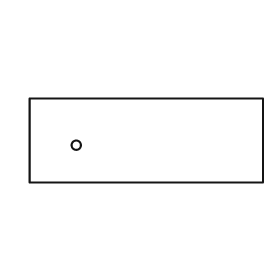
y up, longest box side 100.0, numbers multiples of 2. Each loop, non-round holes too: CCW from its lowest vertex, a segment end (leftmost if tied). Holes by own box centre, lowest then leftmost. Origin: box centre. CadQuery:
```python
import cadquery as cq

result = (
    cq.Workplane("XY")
    .moveTo(-50.0, -18.0)
    .lineTo(50.0, -18.0)
    .lineTo(50.0, 18.0)
    .lineTo(-50.0, 18.0)
    .close()
    .moveTo(-30.0, -2.0)
    .circle(2.0)
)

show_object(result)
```